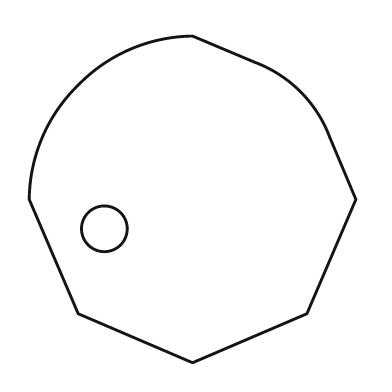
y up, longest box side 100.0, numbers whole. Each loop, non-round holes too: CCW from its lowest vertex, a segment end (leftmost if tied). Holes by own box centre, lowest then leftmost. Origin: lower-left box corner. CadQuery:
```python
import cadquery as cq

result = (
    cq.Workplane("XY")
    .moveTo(50.0, 0.0)
    .lineTo(85.0, 15.0)
    .lineTo(100.0, 50.0)
    .lineTo(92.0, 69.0)
    .threePointArc((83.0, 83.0), (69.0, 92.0))
    .lineTo(50.0, 100.0)
    .threePointArc((31.0, 96.0), (15.0, 85.0))
    .threePointArc((4.0, 69.0), (0.0, 50.0))
    .lineTo(15.0, 15.0)
    .close()
    .moveTo(23.0, 41.0)
    .circle(7.0)
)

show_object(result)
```